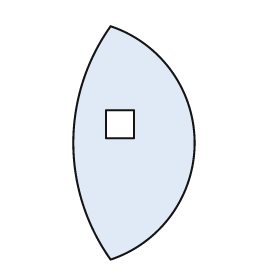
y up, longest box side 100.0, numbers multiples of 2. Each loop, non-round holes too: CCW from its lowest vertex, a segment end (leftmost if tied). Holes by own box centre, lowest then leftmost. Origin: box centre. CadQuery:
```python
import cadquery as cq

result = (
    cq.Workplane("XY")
    .moveTo(-10.0, -50.0)
    .threePointArc((26.0, 0.0), (-10.0, 50.0))
    .threePointArc((-26.0, 0.0), (-10.0, -50.0))
    .close()
    .moveTo(-12.0, 2.0)
    .lineTo(0.0, 2.0)
    .lineTo(0.0, 14.0)
    .lineTo(-12.0, 14.0)
    .close()
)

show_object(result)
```